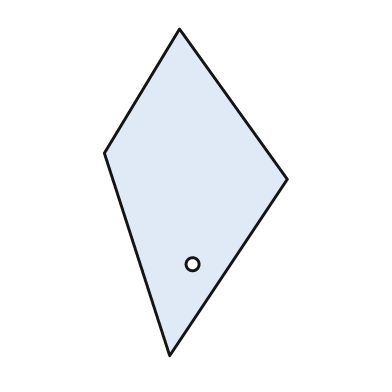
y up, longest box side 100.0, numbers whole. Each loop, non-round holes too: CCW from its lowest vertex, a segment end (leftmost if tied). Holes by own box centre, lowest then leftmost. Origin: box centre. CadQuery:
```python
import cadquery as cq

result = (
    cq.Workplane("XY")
    .moveTo(-8.0, -50.0)
    .lineTo(28.0, 4.0)
    .lineTo(-5.0, 50.0)
    .lineTo(-28.0, 12.0)
    .close()
    .moveTo(-1.0, -22.0)
    .circle(2.0)
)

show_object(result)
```